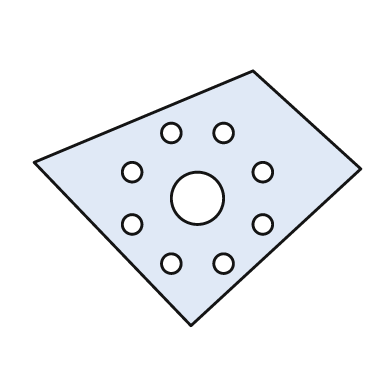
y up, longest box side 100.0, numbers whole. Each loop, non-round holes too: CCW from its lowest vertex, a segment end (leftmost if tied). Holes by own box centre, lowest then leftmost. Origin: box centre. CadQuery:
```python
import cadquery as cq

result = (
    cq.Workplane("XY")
    .moveTo(-2.0, -39.0)
    .lineTo(50.0, 9.0)
    .lineTo(17.0, 39.0)
    .lineTo(-50.0, 11.0)
    .close()
    .moveTo(-8.0, -20.0)
    .circle(3.0)
    .moveTo(8.0, -20.0)
    .circle(3.0)
    .moveTo(-20.0, -8.0)
    .circle(3.0)
    .moveTo(20.0, -8.0)
    .circle(3.0)
    .moveTo(0.0, 0.0)
    .circle(8.0)
    .moveTo(-20.0, 8.0)
    .circle(3.0)
    .moveTo(20.0, 8.0)
    .circle(3.0)
    .moveTo(-8.0, 20.0)
    .circle(3.0)
    .moveTo(8.0, 20.0)
    .circle(3.0)
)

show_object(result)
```